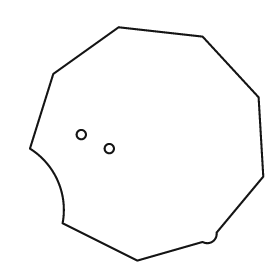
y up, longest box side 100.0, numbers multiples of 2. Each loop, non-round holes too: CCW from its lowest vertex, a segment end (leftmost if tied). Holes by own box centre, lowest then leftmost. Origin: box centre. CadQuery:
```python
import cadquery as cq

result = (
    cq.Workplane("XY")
    .moveTo(-4.0, -50.0)
    .lineTo(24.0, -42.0)
    .threePointArc((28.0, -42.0), (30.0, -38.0))
    .lineTo(50.0, -14.0)
    .lineTo(48.0, 20.0)
    .lineTo(24.0, 46.0)
    .lineTo(-12.0, 50.0)
    .lineTo(-40.0, 30.0)
    .lineTo(-50.0, -2.0)
    .threePointArc((-38.0, -16.0), (-36.0, -34.0))
    .close()
    .moveTo(-16.0, -2.0)
    .circle(2.0)
    .moveTo(-28.0, 4.0)
    .circle(2.0)
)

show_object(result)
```